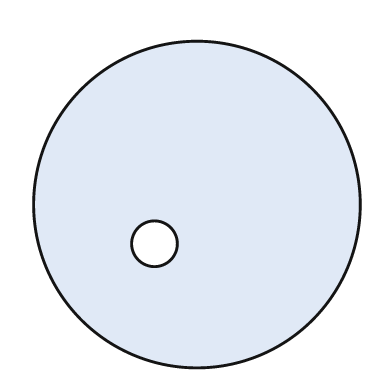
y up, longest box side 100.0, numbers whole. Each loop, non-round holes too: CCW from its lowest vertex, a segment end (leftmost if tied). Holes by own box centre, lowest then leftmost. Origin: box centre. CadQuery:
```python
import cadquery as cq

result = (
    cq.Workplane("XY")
    .moveTo(0.0, 0.0)
    .circle(50.0)
    .moveTo(-13.0, -12.0)
    .circle(7.0)
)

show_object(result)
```